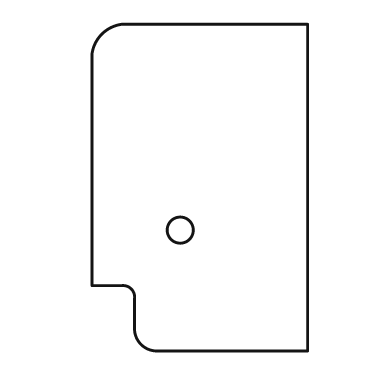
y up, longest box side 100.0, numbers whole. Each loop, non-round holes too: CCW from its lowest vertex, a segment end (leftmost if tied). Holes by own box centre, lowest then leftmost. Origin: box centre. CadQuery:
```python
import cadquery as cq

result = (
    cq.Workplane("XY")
    .moveTo(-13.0, -50.0)
    .lineTo(33.0, -50.0)
    .lineTo(33.0, 50.0)
    .lineTo(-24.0, 50.0)
    .threePointArc((-30.0, 47.0), (-33.0, 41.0))
    .lineTo(-33.0, -30.0)
    .lineTo(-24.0, -30.0)
    .threePointArc((-21.0, -31.0), (-20.0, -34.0))
    .lineTo(-20.0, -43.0)
    .threePointArc((-18.0, -48.0), (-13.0, -50.0))
    .close()
    .moveTo(-6.0, -13.0)
    .circle(4.0)
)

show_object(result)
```